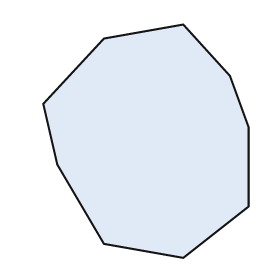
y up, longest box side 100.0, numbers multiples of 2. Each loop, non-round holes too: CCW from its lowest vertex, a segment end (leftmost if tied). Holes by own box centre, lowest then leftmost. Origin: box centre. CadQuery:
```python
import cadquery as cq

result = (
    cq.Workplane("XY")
    .moveTo(16.0, -50.0)
    .lineTo(44.0, -28.0)
    .lineTo(44.0, 6.0)
    .lineTo(36.0, 28.0)
    .lineTo(16.0, 50.0)
    .lineTo(-18.0, 44.0)
    .lineTo(-44.0, 16.0)
    .lineTo(-38.0, -10.0)
    .lineTo(-18.0, -44.0)
    .close()
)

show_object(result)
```